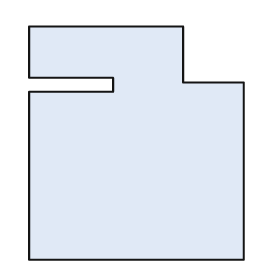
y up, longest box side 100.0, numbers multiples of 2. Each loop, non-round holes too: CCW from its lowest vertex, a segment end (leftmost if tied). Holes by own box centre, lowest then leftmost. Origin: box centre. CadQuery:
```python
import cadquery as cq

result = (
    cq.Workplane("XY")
    .moveTo(-46.0, -50.0)
    .lineTo(46.0, -50.0)
    .lineTo(46.0, 26.0)
    .lineTo(20.0, 26.0)
    .lineTo(20.0, 50.0)
    .lineTo(-46.0, 50.0)
    .lineTo(-46.0, 28.0)
    .lineTo(-10.0, 28.0)
    .lineTo(-10.0, 22.0)
    .lineTo(-46.0, 22.0)
    .close()
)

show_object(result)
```